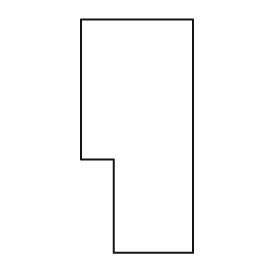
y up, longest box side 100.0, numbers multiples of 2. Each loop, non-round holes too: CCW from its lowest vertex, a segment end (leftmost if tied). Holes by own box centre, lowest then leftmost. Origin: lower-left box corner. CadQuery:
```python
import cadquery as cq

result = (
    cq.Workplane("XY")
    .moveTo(14.0, 0.0)
    .lineTo(48.0, 0.0)
    .lineTo(48.0, 100.0)
    .lineTo(0.0, 100.0)
    .lineTo(0.0, 40.0)
    .lineTo(14.0, 40.0)
    .close()
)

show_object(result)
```